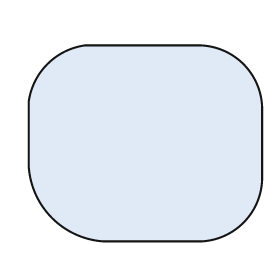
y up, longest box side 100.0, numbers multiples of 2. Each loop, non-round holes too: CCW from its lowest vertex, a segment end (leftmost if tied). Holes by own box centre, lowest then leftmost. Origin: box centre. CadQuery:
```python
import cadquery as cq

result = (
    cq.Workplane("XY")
    .moveTo(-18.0, -42.0)
    .lineTo(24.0, -42.0)
    .threePointArc((42.0, -34.0), (50.0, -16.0))
    .lineTo(50.0, 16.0)
    .threePointArc((42.0, 34.0), (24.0, 42.0))
    .lineTo(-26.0, 42.0)
    .threePointArc((-42.0, 34.0), (-50.0, 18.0))
    .lineTo(-50.0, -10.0)
    .threePointArc((-40.0, -32.0), (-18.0, -42.0))
    .close()
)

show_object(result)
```